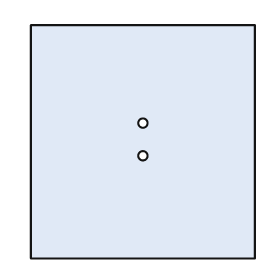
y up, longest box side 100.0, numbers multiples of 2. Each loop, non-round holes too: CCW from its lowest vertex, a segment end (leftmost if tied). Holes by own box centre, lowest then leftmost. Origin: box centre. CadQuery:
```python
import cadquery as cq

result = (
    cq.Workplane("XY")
    .moveTo(-48.0, -50.0)
    .lineTo(48.0, -50.0)
    .lineTo(48.0, 50.0)
    .lineTo(-48.0, 50.0)
    .close()
    .moveTo(0.0, -6.0)
    .circle(2.0)
    .moveTo(0.0, 8.0)
    .circle(2.0)
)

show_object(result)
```